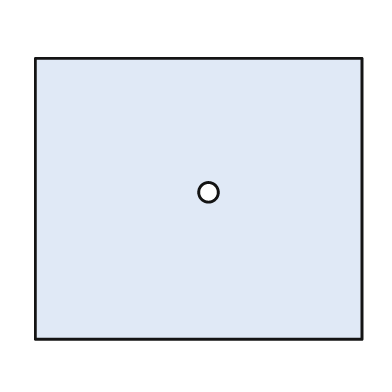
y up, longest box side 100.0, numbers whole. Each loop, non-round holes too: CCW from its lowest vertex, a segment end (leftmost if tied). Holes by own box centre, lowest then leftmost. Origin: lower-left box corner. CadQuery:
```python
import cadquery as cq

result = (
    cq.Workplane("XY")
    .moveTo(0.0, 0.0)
    .lineTo(100.0, 0.0)
    .lineTo(100.0, 86.0)
    .lineTo(0.0, 86.0)
    .close()
    .moveTo(53.0, 45.0)
    .circle(3.0)
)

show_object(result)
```